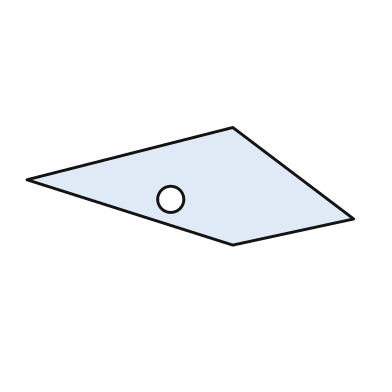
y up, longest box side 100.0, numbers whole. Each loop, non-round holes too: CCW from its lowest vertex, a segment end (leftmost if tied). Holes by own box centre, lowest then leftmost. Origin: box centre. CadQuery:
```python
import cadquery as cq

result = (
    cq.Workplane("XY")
    .moveTo(13.0, -18.0)
    .lineTo(50.0, -10.0)
    .lineTo(13.0, 18.0)
    .lineTo(-50.0, 2.0)
    .close()
    .moveTo(-6.0, -4.0)
    .circle(4.0)
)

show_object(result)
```